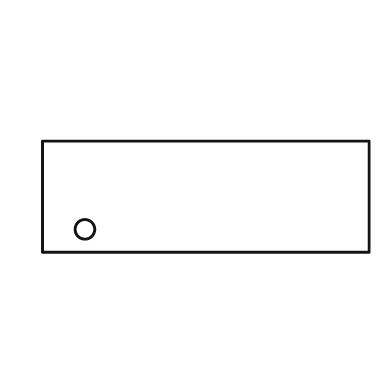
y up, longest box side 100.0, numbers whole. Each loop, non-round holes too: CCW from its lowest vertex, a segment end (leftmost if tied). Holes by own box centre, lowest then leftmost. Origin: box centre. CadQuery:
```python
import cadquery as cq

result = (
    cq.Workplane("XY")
    .moveTo(-50.0, -17.0)
    .lineTo(50.0, -17.0)
    .lineTo(50.0, 17.0)
    .lineTo(-50.0, 17.0)
    .close()
    .moveTo(-37.0, -10.0)
    .circle(3.0)
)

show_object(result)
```